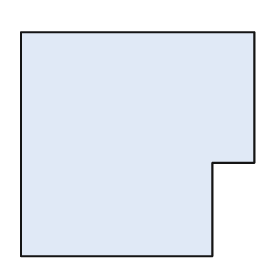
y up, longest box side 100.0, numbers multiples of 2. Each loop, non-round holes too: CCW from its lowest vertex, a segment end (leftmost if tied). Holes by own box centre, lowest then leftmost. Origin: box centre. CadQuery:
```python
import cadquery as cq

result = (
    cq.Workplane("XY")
    .moveTo(-50.0, -48.0)
    .lineTo(32.0, -48.0)
    .lineTo(32.0, -8.0)
    .lineTo(50.0, -8.0)
    .lineTo(50.0, 48.0)
    .lineTo(-50.0, 48.0)
    .close()
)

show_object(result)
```